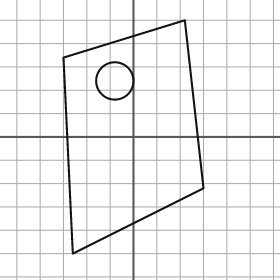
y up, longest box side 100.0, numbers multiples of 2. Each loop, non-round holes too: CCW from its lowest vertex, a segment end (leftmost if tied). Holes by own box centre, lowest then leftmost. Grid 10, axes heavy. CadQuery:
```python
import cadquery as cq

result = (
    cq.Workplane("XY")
    .moveTo(-26.0, -50.0)
    .lineTo(30.0, -22.0)
    .lineTo(22.0, 50.0)
    .lineTo(-30.0, 34.0)
    .close()
    .moveTo(-8.0, 24.0)
    .circle(8.0)
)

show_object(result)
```